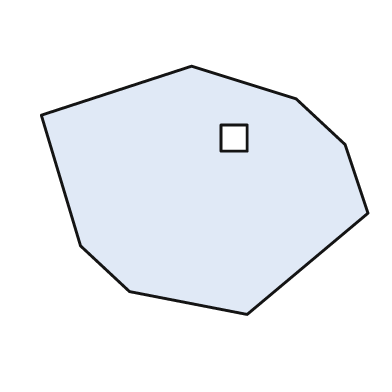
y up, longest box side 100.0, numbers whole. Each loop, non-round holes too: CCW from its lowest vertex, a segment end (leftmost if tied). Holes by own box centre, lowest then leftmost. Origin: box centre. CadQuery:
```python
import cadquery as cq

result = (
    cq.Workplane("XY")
    .moveTo(13.0, -38.0)
    .lineTo(50.0, -7.0)
    .lineTo(43.0, 14.0)
    .lineTo(28.0, 28.0)
    .lineTo(-4.0, 38.0)
    .lineTo(-50.0, 23.0)
    .lineTo(-38.0, -17.0)
    .lineTo(-23.0, -31.0)
    .close()
    .moveTo(5.0, 12.0)
    .lineTo(13.0, 12.0)
    .lineTo(13.0, 20.0)
    .lineTo(5.0, 20.0)
    .close()
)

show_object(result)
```